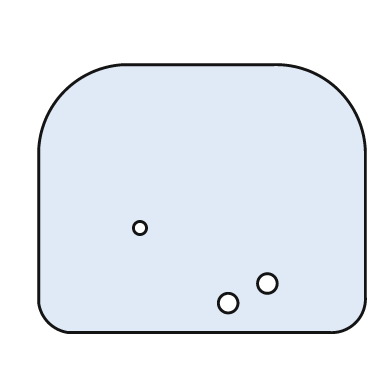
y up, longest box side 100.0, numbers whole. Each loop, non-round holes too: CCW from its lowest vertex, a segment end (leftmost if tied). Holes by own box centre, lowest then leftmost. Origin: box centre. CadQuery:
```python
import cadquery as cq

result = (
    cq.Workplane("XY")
    .moveTo(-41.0, -41.0)
    .lineTo(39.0, -41.0)
    .threePointArc((47.0, -38.0), (50.0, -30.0))
    .lineTo(50.0, 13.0)
    .threePointArc((42.0, 33.0), (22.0, 41.0))
    .lineTo(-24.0, 41.0)
    .threePointArc((-42.0, 33.0), (-50.0, 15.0))
    .lineTo(-50.0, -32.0)
    .threePointArc((-47.0, -38.0), (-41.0, -41.0))
    .close()
    .moveTo(8.0, -32.0)
    .circle(3.0)
    .moveTo(20.0, -26.0)
    .circle(3.0)
    .moveTo(-19.0, -9.0)
    .circle(2.0)
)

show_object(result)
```